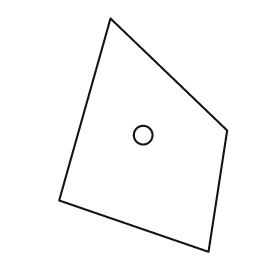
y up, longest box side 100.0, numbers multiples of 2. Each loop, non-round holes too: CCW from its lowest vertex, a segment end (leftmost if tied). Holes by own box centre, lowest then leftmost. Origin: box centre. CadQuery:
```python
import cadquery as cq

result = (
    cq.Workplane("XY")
    .moveTo(28.0, -50.0)
    .lineTo(36.0, 2.0)
    .lineTo(-14.0, 50.0)
    .lineTo(-36.0, -28.0)
    .close()
    .moveTo(0.0, 0.0)
    .circle(4.0)
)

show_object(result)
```